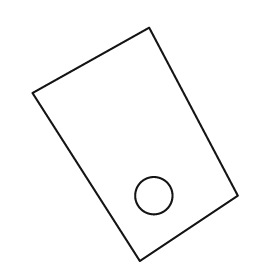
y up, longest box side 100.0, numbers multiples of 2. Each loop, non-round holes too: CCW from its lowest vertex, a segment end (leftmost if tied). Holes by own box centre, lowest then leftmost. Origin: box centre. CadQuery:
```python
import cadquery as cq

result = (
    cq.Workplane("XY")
    .moveTo(2.0, -50.0)
    .lineTo(44.0, -22.0)
    .lineTo(6.0, 50.0)
    .lineTo(-44.0, 22.0)
    .close()
    .moveTo(8.0, -22.0)
    .circle(8.0)
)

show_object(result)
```